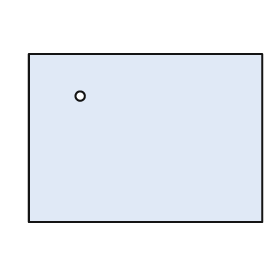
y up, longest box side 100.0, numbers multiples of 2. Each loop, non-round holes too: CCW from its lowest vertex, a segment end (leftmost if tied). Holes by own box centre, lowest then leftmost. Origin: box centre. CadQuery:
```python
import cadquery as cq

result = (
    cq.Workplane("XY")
    .moveTo(-50.0, -36.0)
    .lineTo(50.0, -36.0)
    .lineTo(50.0, 36.0)
    .lineTo(-50.0, 36.0)
    .close()
    .moveTo(-28.0, 18.0)
    .circle(2.0)
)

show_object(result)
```